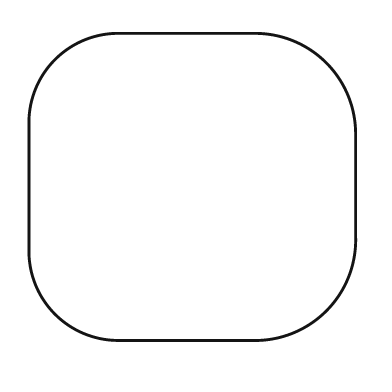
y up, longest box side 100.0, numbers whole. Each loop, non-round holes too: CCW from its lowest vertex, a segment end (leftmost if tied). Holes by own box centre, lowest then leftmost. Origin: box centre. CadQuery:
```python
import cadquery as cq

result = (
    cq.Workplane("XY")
    .moveTo(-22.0, -47.0)
    .lineTo(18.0, -47.0)
    .threePointArc((41.0, -38.0), (50.0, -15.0))
    .lineTo(50.0, 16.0)
    .threePointArc((41.0, 38.0), (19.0, 47.0))
    .lineTo(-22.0, 47.0)
    .threePointArc((-42.0, 39.0), (-50.0, 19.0))
    .lineTo(-50.0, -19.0)
    .threePointArc((-42.0, -39.0), (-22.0, -47.0))
    .close()
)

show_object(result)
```